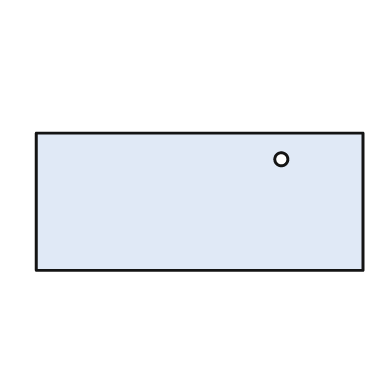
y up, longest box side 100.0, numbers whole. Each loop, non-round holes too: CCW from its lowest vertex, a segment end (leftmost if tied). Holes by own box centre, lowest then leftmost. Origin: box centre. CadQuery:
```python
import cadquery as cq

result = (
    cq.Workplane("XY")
    .moveTo(-50.0, -21.0)
    .lineTo(50.0, -21.0)
    .lineTo(50.0, 21.0)
    .lineTo(-50.0, 21.0)
    .close()
    .moveTo(25.0, 13.0)
    .circle(2.0)
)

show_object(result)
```